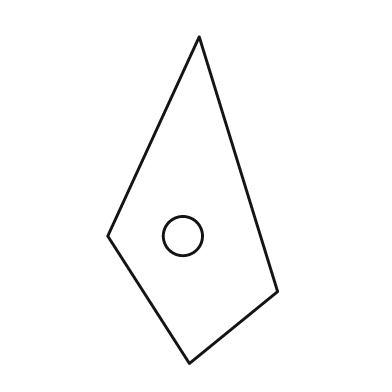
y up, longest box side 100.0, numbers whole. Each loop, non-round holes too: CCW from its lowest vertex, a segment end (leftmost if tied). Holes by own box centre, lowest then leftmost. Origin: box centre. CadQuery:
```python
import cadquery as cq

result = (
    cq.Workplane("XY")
    .moveTo(-1.0, -50.0)
    .lineTo(26.0, -28.0)
    .lineTo(2.0, 50.0)
    .lineTo(-26.0, -11.0)
    .close()
    .moveTo(-3.0, -11.0)
    .circle(6.0)
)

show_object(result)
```